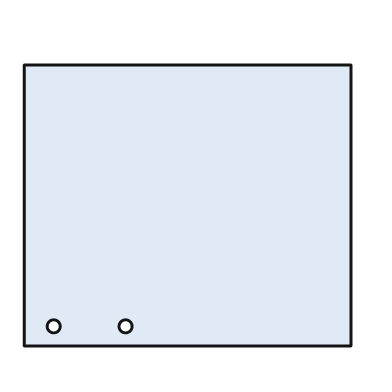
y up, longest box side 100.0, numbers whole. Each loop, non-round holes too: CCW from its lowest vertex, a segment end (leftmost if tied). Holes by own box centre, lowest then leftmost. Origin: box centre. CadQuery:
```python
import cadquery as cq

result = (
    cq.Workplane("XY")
    .moveTo(-50.0, -43.0)
    .lineTo(50.0, -43.0)
    .lineTo(50.0, 43.0)
    .lineTo(-50.0, 43.0)
    .close()
    .moveTo(-41.0, -37.0)
    .circle(2.0)
    .moveTo(-19.0, -37.0)
    .circle(2.0)
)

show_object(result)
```